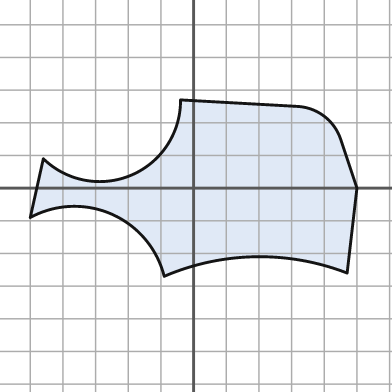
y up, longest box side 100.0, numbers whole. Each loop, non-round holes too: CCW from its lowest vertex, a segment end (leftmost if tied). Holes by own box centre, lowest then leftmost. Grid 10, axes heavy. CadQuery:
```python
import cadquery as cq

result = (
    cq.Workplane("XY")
    .moveTo(-9.0, -27.0)
    .threePointArc((19.0, -21.0), (47.0, -26.0))
    .lineTo(50.0, 0.0)
    .lineTo(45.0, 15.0)
    .threePointArc((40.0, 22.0), (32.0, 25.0))
    .lineTo(-4.0, 27.0)
    .threePointArc((-19.0, 4.0), (-46.0, 9.0))
    .lineTo(-50.0, -9.0)
    .threePointArc((-25.0, -8.0), (-9.0, -27.0))
    .close()
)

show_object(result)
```